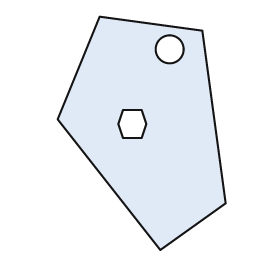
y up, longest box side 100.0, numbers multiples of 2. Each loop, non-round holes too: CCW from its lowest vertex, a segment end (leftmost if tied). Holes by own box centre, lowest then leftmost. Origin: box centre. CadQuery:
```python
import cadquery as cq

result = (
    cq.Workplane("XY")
    .moveTo(8.0, -50.0)
    .lineTo(36.0, -30.0)
    .lineTo(26.0, 44.0)
    .lineTo(-18.0, 50.0)
    .lineTo(-36.0, 6.0)
    .close()
    .moveTo(-8.0, -2.0)
    .lineTo(0.0, -2.0)
    .lineTo(2.0, 4.0)
    .lineTo(0.0, 10.0)
    .lineTo(-8.0, 10.0)
    .lineTo(-10.0, 4.0)
    .close()
    .moveTo(12.0, 36.0)
    .circle(6.0)
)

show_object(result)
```